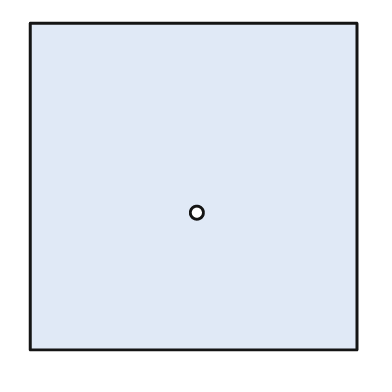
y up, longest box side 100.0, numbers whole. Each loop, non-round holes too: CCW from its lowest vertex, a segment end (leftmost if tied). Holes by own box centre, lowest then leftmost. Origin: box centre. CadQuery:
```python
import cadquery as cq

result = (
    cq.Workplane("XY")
    .moveTo(-50.0, -50.0)
    .lineTo(50.0, -50.0)
    .lineTo(50.0, 50.0)
    .lineTo(-50.0, 50.0)
    .close()
    .moveTo(1.0, -8.0)
    .circle(2.0)
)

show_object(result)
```